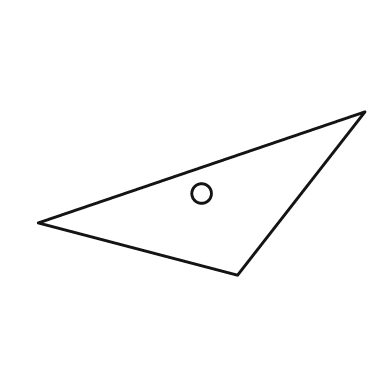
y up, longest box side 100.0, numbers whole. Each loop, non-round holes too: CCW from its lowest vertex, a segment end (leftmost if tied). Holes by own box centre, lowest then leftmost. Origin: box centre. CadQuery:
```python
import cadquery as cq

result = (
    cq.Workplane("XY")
    .moveTo(11.0, -25.0)
    .lineTo(50.0, 25.0)
    .lineTo(-50.0, -9.0)
    .close()
    .moveTo(0.0, 0.0)
    .circle(3.0)
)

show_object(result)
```